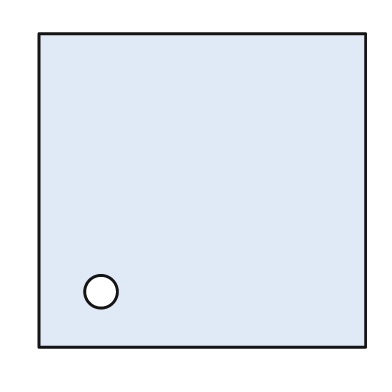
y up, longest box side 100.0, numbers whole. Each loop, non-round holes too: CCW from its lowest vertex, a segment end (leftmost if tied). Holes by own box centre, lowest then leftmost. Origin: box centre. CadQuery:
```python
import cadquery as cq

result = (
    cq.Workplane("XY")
    .moveTo(-50.0, -48.0)
    .lineTo(50.0, -48.0)
    .lineTo(50.0, 48.0)
    .lineTo(-50.0, 48.0)
    .close()
    .moveTo(-31.0, -31.0)
    .circle(5.0)
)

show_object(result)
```